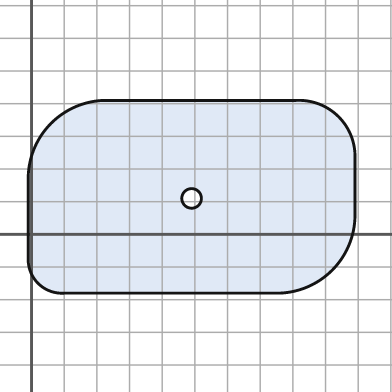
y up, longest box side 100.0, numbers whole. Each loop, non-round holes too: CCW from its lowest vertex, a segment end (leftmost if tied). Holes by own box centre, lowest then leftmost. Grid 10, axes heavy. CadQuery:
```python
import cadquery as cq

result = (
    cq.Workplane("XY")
    .moveTo(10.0, -18.0)
    .lineTo(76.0, -18.0)
    .threePointArc((92.0, -11.0), (99.0, 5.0))
    .lineTo(99.0, 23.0)
    .threePointArc((94.0, 36.0), (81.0, 41.0))
    .lineTo(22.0, 41.0)
    .threePointArc((6.0, 34.0), (-1.0, 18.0))
    .lineTo(-1.0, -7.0)
    .threePointArc((2.0, -15.0), (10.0, -18.0))
    .close()
    .moveTo(49.0, 11.0)
    .circle(3.0)
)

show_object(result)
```